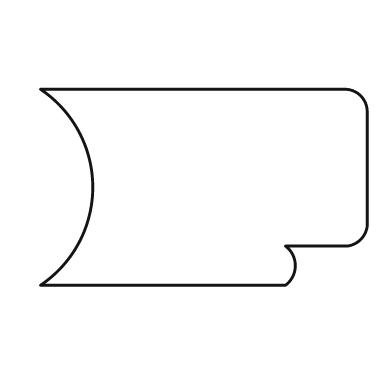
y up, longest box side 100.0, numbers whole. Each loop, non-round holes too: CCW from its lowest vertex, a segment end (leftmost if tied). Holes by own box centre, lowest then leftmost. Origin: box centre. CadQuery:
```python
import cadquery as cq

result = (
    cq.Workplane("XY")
    .moveTo(-50.0, -30.0)
    .lineTo(25.0, -30.0)
    .threePointArc((28.0, -24.0), (25.0, -18.0))
    .lineTo(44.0, -18.0)
    .threePointArc((48.0, -16.0), (50.0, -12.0))
    .lineTo(50.0, 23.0)
    .threePointArc((48.0, 28.0), (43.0, 30.0))
    .lineTo(-50.0, 30.0)
    .threePointArc((-34.0, 0.0), (-50.0, -30.0))
    .close()
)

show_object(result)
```